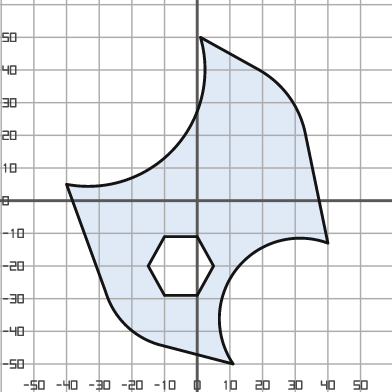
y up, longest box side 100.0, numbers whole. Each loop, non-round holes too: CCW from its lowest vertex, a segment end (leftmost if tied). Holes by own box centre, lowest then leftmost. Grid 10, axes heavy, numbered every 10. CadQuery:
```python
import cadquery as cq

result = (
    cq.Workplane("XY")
    .moveTo(11.0, -50.0)
    .threePointArc((12.0, -21.0), (40.0, -13.0))
    .lineTo(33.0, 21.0)
    .threePointArc((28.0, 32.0), (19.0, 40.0))
    .lineTo(1.0, 50.0)
    .threePointArc((-7.0, 16.0), (-40.0, 5.0))
    .lineTo(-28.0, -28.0)
    .threePointArc((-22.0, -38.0), (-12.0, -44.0))
    .close()
    .moveTo(-10.0, -29.0)
    .lineTo(0.0, -29.0)
    .lineTo(5.0, -20.0)
    .lineTo(0.0, -11.0)
    .lineTo(-10.0, -11.0)
    .lineTo(-15.0, -20.0)
    .close()
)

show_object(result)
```